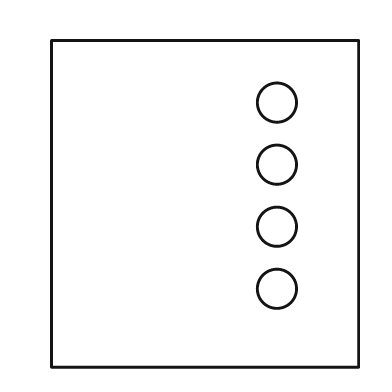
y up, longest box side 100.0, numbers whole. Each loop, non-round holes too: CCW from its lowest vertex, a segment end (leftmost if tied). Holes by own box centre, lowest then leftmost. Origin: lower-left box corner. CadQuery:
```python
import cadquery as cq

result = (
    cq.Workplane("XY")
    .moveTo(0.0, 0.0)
    .lineTo(94.0, 0.0)
    .lineTo(94.0, 100.0)
    .lineTo(0.0, 100.0)
    .close()
    .moveTo(69.0, 24.0)
    .circle(6.0)
    .moveTo(69.0, 43.0)
    .circle(6.0)
    .moveTo(69.0, 62.0)
    .circle(6.0)
    .moveTo(69.0, 81.0)
    .circle(6.0)
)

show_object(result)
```